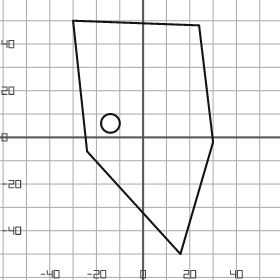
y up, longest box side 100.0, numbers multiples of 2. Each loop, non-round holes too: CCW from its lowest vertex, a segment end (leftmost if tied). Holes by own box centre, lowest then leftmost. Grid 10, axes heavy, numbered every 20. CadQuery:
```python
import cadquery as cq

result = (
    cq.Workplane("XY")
    .moveTo(16.0, -50.0)
    .lineTo(30.0, -2.0)
    .lineTo(24.0, 48.0)
    .lineTo(-30.0, 50.0)
    .lineTo(-24.0, -6.0)
    .close()
    .moveTo(-14.0, 6.0)
    .circle(4.0)
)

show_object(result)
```